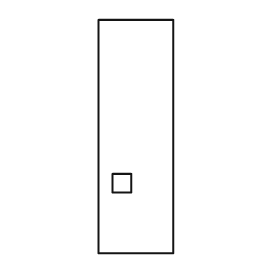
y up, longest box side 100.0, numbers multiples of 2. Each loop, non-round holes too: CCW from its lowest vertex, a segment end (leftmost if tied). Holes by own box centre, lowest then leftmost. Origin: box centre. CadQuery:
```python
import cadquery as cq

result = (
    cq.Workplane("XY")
    .moveTo(-16.0, -50.0)
    .lineTo(16.0, -50.0)
    .lineTo(16.0, 50.0)
    .lineTo(-16.0, 50.0)
    .close()
    .moveTo(-10.0, -24.0)
    .lineTo(-2.0, -24.0)
    .lineTo(-2.0, -16.0)
    .lineTo(-10.0, -16.0)
    .close()
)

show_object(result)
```